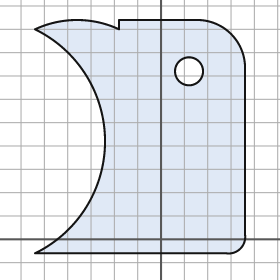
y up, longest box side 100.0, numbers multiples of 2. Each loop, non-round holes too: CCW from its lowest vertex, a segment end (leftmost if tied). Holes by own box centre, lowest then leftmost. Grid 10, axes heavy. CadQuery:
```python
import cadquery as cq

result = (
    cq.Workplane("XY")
    .moveTo(-54.0, -6.0)
    .lineTo(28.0, -6.0)
    .threePointArc((34.0, -4.0), (36.0, 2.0))
    .lineTo(36.0, 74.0)
    .threePointArc((30.0, 88.0), (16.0, 94.0))
    .lineTo(-18.0, 94.0)
    .lineTo(-18.0, 90.0)
    .threePointArc((-36.0, 94.0), (-54.0, 90.0))
    .threePointArc((-24.0, 42.0), (-54.0, -6.0))
    .close()
    .moveTo(12.0, 72.0)
    .circle(6.0)
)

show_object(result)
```